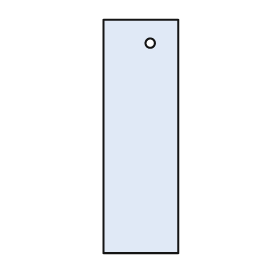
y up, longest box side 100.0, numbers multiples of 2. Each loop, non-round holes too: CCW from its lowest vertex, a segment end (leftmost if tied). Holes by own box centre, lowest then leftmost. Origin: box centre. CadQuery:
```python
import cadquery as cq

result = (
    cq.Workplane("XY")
    .moveTo(-16.0, -50.0)
    .lineTo(16.0, -50.0)
    .lineTo(16.0, 50.0)
    .lineTo(-16.0, 50.0)
    .close()
    .moveTo(4.0, 40.0)
    .circle(2.0)
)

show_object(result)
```